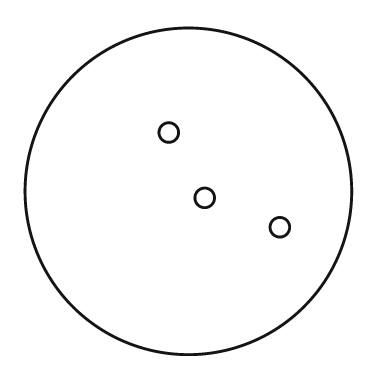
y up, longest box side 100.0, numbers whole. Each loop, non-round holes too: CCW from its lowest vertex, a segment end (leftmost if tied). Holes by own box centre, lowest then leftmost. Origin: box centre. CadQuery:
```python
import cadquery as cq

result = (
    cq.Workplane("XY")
    .moveTo(0.0, 0.0)
    .circle(50.0)
    .moveTo(28.0, -11.0)
    .circle(3.0)
    .moveTo(5.0, -2.0)
    .circle(3.0)
    .moveTo(-6.0, 18.0)
    .circle(3.0)
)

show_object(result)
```